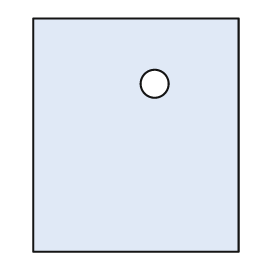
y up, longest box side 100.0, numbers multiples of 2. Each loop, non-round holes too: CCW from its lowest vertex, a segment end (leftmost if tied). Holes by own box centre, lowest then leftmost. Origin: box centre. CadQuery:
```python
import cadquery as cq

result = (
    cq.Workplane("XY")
    .moveTo(-44.0, -50.0)
    .lineTo(44.0, -50.0)
    .lineTo(44.0, 50.0)
    .lineTo(-44.0, 50.0)
    .close()
    .moveTo(8.0, 22.0)
    .circle(6.0)
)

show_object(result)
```